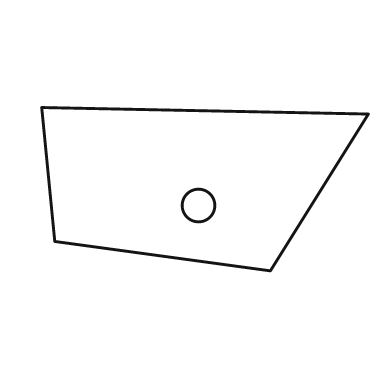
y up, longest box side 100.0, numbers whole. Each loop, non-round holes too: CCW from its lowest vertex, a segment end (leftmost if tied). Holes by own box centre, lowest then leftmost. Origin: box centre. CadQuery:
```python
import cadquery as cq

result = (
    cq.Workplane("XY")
    .moveTo(20.0, -25.0)
    .lineTo(50.0, 23.0)
    .lineTo(-50.0, 25.0)
    .lineTo(-46.0, -16.0)
    .close()
    .moveTo(-2.0, -5.0)
    .circle(5.0)
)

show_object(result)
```